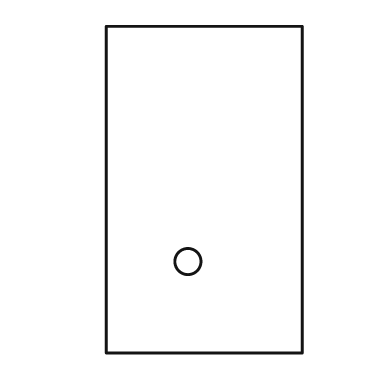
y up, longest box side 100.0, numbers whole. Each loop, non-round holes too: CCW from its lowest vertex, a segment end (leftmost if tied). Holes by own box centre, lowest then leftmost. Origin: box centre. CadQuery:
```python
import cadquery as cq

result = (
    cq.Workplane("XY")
    .moveTo(-30.0, -50.0)
    .lineTo(30.0, -50.0)
    .lineTo(30.0, 50.0)
    .lineTo(-30.0, 50.0)
    .close()
    .moveTo(-5.0, -22.0)
    .circle(4.0)
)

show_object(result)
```